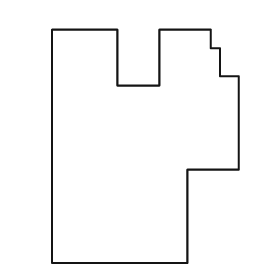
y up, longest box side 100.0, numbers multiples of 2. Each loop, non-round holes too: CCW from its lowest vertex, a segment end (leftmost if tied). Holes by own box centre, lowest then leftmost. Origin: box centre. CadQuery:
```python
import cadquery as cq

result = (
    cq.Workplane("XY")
    .moveTo(-40.0, -50.0)
    .lineTo(18.0, -50.0)
    .lineTo(18.0, -10.0)
    .lineTo(40.0, -10.0)
    .lineTo(40.0, 30.0)
    .lineTo(32.0, 30.0)
    .lineTo(32.0, 42.0)
    .lineTo(28.0, 42.0)
    .lineTo(28.0, 50.0)
    .lineTo(6.0, 50.0)
    .lineTo(6.0, 26.0)
    .lineTo(-12.0, 26.0)
    .lineTo(-12.0, 50.0)
    .lineTo(-40.0, 50.0)
    .close()
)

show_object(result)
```